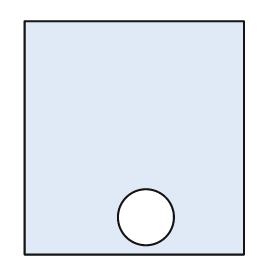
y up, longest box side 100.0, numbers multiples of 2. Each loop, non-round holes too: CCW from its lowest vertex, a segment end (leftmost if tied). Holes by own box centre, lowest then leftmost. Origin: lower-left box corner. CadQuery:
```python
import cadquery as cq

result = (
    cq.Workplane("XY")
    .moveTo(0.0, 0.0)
    .lineTo(94.0, 0.0)
    .lineTo(94.0, 100.0)
    .lineTo(0.0, 100.0)
    .close()
    .moveTo(52.0, 16.0)
    .circle(12.0)
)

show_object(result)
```